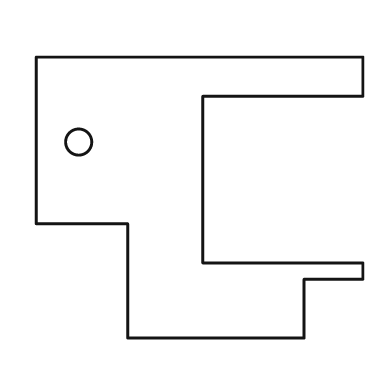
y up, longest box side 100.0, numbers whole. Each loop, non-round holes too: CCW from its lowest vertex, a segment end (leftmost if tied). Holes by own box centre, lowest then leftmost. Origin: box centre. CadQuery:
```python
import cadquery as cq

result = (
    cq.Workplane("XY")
    .moveTo(-22.0, -43.0)
    .lineTo(32.0, -43.0)
    .lineTo(32.0, -25.0)
    .lineTo(50.0, -25.0)
    .lineTo(50.0, -20.0)
    .lineTo(1.0, -20.0)
    .lineTo(1.0, 31.0)
    .lineTo(50.0, 31.0)
    .lineTo(50.0, 43.0)
    .lineTo(-50.0, 43.0)
    .lineTo(-50.0, -8.0)
    .lineTo(-22.0, -8.0)
    .close()
    .moveTo(-37.0, 17.0)
    .circle(4.0)
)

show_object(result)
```